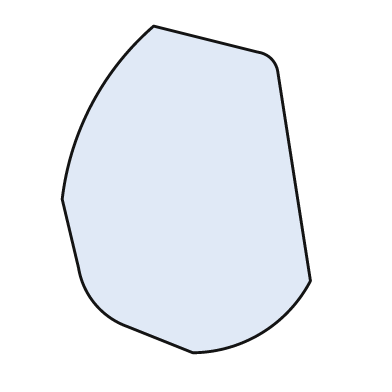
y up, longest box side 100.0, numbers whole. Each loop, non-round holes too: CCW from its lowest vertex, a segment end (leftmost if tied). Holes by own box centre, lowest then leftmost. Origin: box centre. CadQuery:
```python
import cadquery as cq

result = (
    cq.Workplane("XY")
    .moveTo(2.0, -50.0)
    .threePointArc((23.0, -44.0), (38.0, -28.0))
    .lineTo(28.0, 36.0)
    .threePointArc((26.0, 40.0), (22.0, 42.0))
    .lineTo(-10.0, 50.0)
    .threePointArc((-29.0, 26.0), (-38.0, -3.0))
    .lineTo(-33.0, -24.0)
    .threePointArc((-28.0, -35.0), (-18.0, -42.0))
    .close()
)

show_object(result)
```